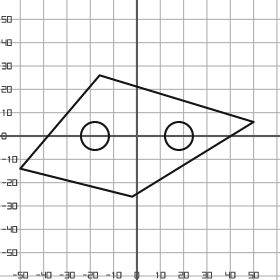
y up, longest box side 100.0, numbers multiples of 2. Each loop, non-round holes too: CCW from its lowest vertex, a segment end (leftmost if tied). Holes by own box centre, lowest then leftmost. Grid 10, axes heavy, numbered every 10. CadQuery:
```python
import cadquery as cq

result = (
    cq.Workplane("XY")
    .moveTo(-2.0, -26.0)
    .lineTo(50.0, 6.0)
    .lineTo(-16.0, 26.0)
    .lineTo(-50.0, -14.0)
    .close()
    .moveTo(-18.0, 0.0)
    .circle(6.0)
    .moveTo(18.0, 0.0)
    .circle(6.0)
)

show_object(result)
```